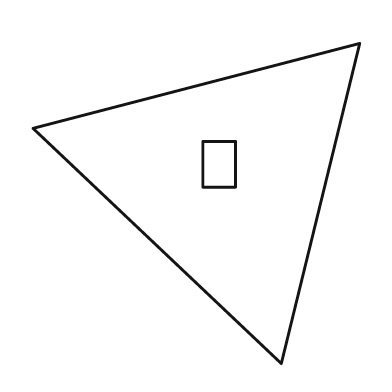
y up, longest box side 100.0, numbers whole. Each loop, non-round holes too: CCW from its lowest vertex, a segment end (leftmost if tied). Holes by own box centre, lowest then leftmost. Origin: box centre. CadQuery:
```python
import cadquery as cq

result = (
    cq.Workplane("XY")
    .moveTo(26.0, -49.0)
    .lineTo(50.0, 49.0)
    .lineTo(-50.0, 23.0)
    .close()
    .moveTo(2.0, 5.0)
    .lineTo(12.0, 5.0)
    .lineTo(12.0, 19.0)
    .lineTo(2.0, 19.0)
    .close()
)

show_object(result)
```